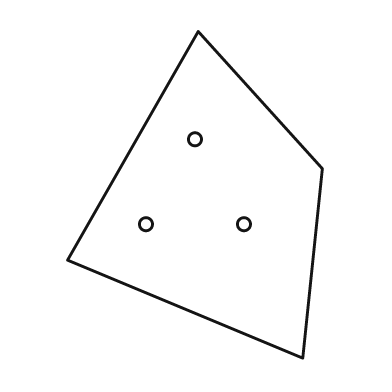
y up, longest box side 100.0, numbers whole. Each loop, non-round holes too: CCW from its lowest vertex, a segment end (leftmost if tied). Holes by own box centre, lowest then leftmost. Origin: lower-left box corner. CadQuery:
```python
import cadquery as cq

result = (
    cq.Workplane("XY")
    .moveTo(72.0, 0.0)
    .lineTo(78.0, 58.0)
    .lineTo(40.0, 100.0)
    .lineTo(0.0, 30.0)
    .close()
    .moveTo(24.0, 41.0)
    .circle(2.0)
    .moveTo(54.0, 41.0)
    .circle(2.0)
    .moveTo(39.0, 67.0)
    .circle(2.0)
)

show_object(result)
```